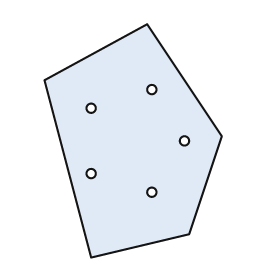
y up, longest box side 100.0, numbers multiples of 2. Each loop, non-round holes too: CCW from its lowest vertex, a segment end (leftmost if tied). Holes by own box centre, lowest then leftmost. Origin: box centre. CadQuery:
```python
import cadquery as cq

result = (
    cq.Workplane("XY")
    .moveTo(-18.0, -50.0)
    .lineTo(24.0, -40.0)
    .lineTo(38.0, 2.0)
    .lineTo(6.0, 50.0)
    .lineTo(-38.0, 26.0)
    .close()
    .moveTo(8.0, -22.0)
    .circle(2.0)
    .moveTo(-18.0, -14.0)
    .circle(2.0)
    .moveTo(22.0, 0.0)
    .circle(2.0)
    .moveTo(-18.0, 14.0)
    .circle(2.0)
    .moveTo(8.0, 22.0)
    .circle(2.0)
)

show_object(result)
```